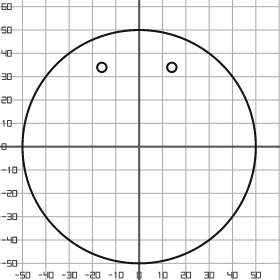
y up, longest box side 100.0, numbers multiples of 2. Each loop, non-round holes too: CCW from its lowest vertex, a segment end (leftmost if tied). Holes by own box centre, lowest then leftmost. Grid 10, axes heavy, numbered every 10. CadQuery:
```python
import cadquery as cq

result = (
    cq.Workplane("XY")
    .moveTo(0.0, 0.0)
    .circle(50.0)
    .moveTo(-16.0, 34.0)
    .circle(2.0)
    .moveTo(14.0, 34.0)
    .circle(2.0)
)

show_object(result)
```